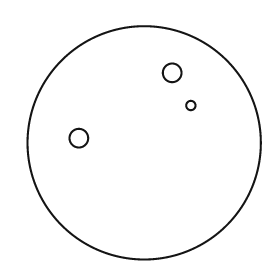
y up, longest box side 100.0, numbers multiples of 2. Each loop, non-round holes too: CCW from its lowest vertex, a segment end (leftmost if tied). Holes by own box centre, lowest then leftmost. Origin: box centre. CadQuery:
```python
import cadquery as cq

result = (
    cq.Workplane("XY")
    .moveTo(0.0, 0.0)
    .circle(50.0)
    .moveTo(-28.0, 2.0)
    .circle(4.0)
    .moveTo(20.0, 16.0)
    .circle(2.0)
    .moveTo(12.0, 30.0)
    .circle(4.0)
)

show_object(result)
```